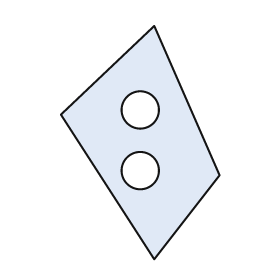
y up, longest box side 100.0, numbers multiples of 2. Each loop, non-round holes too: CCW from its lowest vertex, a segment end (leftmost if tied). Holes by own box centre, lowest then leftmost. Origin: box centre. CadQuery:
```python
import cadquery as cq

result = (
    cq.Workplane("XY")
    .moveTo(6.0, -50.0)
    .lineTo(34.0, -14.0)
    .lineTo(6.0, 50.0)
    .lineTo(-34.0, 12.0)
    .close()
    .moveTo(0.0, -12.0)
    .circle(8.0)
    .moveTo(0.0, 14.0)
    .circle(8.0)
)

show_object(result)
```